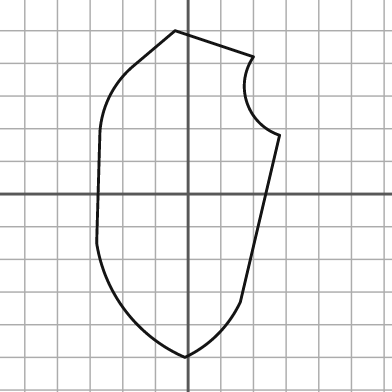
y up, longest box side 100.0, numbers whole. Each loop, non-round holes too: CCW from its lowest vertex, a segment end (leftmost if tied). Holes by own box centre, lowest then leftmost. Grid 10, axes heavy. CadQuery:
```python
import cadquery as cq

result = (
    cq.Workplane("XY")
    .moveTo(-1.0, -50.0)
    .threePointArc((9.0, -43.0), (16.0, -33.0))
    .lineTo(28.0, 18.0)
    .threePointArc((18.0, 28.0), (20.0, 42.0))
    .lineTo(-4.0, 50.0)
    .lineTo(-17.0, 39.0)
    .threePointArc((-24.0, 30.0), (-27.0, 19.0))
    .lineTo(-28.0, -15.0)
    .threePointArc((-19.0, -36.0), (-1.0, -50.0))
    .close()
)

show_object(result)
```